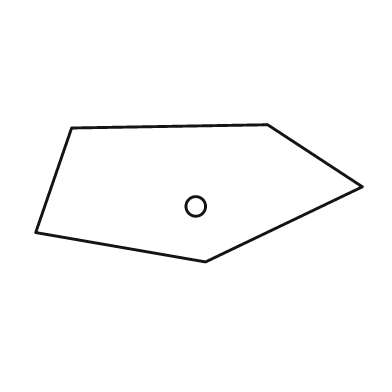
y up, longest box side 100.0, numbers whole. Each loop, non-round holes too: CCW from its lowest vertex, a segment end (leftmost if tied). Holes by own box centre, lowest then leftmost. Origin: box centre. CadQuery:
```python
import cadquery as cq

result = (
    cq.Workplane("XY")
    .moveTo(2.0, -21.0)
    .lineTo(50.0, 2.0)
    .lineTo(21.0, 21.0)
    .lineTo(-39.0, 20.0)
    .lineTo(-50.0, -12.0)
    .close()
    .moveTo(-1.0, -4.0)
    .circle(3.0)
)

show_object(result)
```